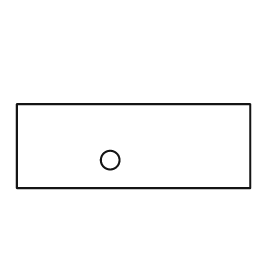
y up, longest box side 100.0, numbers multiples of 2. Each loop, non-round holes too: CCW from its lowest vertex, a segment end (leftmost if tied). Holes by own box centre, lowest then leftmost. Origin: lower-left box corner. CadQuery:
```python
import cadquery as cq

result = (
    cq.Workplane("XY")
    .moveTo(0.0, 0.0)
    .lineTo(100.0, 0.0)
    .lineTo(100.0, 36.0)
    .lineTo(0.0, 36.0)
    .close()
    .moveTo(40.0, 12.0)
    .circle(4.0)
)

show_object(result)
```